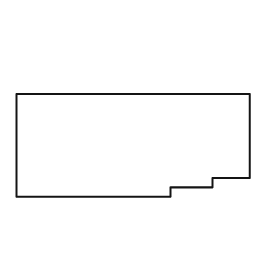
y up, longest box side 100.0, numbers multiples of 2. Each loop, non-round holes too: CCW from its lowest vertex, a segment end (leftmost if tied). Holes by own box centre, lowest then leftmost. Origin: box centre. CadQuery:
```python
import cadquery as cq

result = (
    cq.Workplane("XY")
    .moveTo(-50.0, -22.0)
    .lineTo(16.0, -22.0)
    .lineTo(16.0, -18.0)
    .lineTo(34.0, -18.0)
    .lineTo(34.0, -14.0)
    .lineTo(50.0, -14.0)
    .lineTo(50.0, 22.0)
    .lineTo(-50.0, 22.0)
    .close()
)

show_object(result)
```